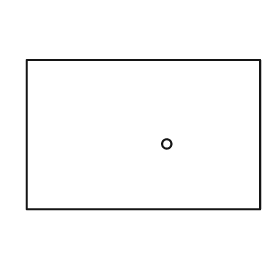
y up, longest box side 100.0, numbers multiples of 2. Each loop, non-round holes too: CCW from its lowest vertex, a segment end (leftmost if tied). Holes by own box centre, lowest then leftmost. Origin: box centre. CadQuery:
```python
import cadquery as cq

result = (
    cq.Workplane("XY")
    .moveTo(-50.0, -32.0)
    .lineTo(50.0, -32.0)
    .lineTo(50.0, 32.0)
    .lineTo(-50.0, 32.0)
    .close()
    .moveTo(10.0, -4.0)
    .circle(2.0)
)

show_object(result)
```